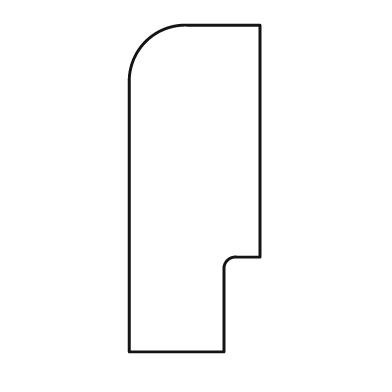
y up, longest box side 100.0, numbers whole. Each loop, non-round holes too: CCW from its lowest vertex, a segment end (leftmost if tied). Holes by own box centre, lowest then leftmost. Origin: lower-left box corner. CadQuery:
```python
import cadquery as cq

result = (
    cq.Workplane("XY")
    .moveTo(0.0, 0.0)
    .lineTo(29.0, 0.0)
    .lineTo(29.0, 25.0)
    .threePointArc((30.0, 28.0), (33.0, 29.0))
    .lineTo(40.0, 29.0)
    .lineTo(40.0, 100.0)
    .lineTo(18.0, 100.0)
    .threePointArc((5.0, 95.0), (0.0, 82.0))
    .close()
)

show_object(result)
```